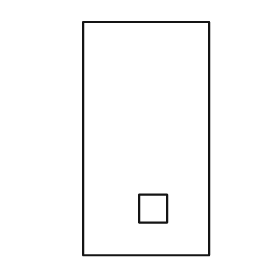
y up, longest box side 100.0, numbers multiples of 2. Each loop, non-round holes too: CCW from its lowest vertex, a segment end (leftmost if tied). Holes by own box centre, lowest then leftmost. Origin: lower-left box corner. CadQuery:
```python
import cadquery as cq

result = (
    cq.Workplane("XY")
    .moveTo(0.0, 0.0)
    .lineTo(54.0, 0.0)
    .lineTo(54.0, 100.0)
    .lineTo(0.0, 100.0)
    .close()
    .moveTo(24.0, 14.0)
    .lineTo(36.0, 14.0)
    .lineTo(36.0, 26.0)
    .lineTo(24.0, 26.0)
    .close()
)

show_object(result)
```